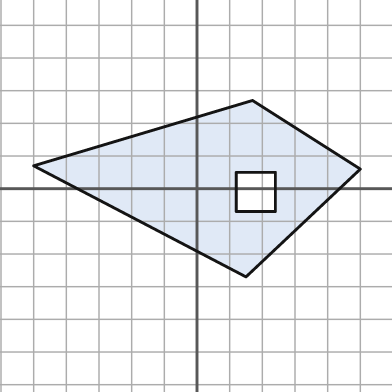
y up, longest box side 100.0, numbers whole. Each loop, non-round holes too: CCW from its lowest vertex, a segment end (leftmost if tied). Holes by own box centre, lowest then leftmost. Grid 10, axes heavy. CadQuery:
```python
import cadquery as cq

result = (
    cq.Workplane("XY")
    .moveTo(15.0, -27.0)
    .lineTo(50.0, 6.0)
    .lineTo(17.0, 27.0)
    .lineTo(-50.0, 7.0)
    .close()
    .moveTo(12.0, -7.0)
    .lineTo(24.0, -7.0)
    .lineTo(24.0, 5.0)
    .lineTo(12.0, 5.0)
    .close()
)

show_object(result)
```